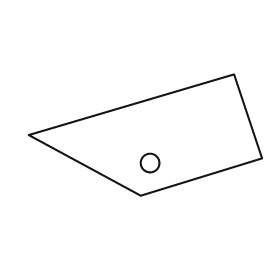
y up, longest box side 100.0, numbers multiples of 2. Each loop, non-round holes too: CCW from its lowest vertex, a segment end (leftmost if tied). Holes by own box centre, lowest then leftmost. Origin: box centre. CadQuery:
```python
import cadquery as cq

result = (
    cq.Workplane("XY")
    .moveTo(-2.0, -26.0)
    .lineTo(50.0, -10.0)
    .lineTo(38.0, 26.0)
    .lineTo(-50.0, 0.0)
    .close()
    .moveTo(2.0, -12.0)
    .circle(4.0)
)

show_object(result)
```